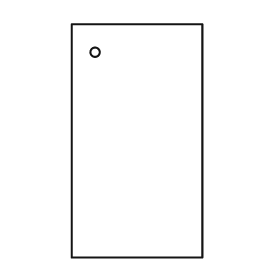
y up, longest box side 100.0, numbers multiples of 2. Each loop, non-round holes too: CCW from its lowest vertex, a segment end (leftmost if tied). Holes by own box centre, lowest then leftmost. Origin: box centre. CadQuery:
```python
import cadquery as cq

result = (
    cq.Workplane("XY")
    .moveTo(-28.0, -50.0)
    .lineTo(28.0, -50.0)
    .lineTo(28.0, 50.0)
    .lineTo(-28.0, 50.0)
    .close()
    .moveTo(-18.0, 38.0)
    .circle(2.0)
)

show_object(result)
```